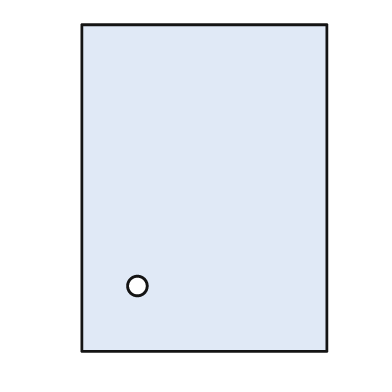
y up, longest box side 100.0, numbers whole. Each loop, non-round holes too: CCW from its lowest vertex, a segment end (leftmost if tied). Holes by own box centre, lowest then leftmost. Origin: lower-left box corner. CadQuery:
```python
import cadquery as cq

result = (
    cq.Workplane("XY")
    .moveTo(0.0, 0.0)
    .lineTo(75.0, 0.0)
    .lineTo(75.0, 100.0)
    .lineTo(0.0, 100.0)
    .close()
    .moveTo(17.0, 20.0)
    .circle(3.0)
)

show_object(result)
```